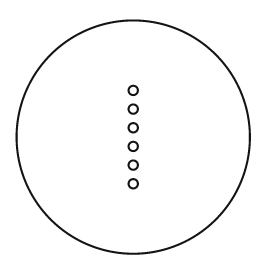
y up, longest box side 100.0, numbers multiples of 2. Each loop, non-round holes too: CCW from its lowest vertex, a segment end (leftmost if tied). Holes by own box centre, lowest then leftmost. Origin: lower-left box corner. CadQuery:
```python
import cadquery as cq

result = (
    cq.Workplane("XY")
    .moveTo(50.0, 50.0)
    .circle(50.0)
    .moveTo(50.0, 30.0)
    .circle(2.0)
    .moveTo(50.0, 38.0)
    .circle(2.0)
    .moveTo(50.0, 46.0)
    .circle(2.0)
    .moveTo(50.0, 54.0)
    .circle(2.0)
    .moveTo(50.0, 62.0)
    .circle(2.0)
    .moveTo(50.0, 70.0)
    .circle(2.0)
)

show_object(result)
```